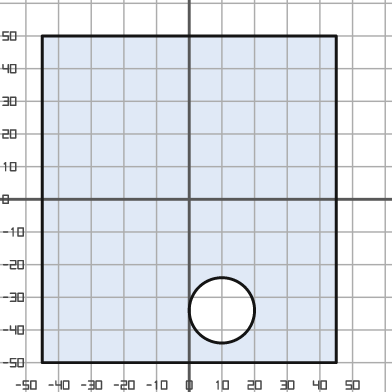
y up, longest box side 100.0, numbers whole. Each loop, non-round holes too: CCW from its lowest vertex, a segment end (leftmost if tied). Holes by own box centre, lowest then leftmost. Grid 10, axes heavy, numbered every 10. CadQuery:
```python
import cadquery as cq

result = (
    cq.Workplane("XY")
    .moveTo(-45.0, -50.0)
    .lineTo(45.0, -50.0)
    .lineTo(45.0, 50.0)
    .lineTo(-45.0, 50.0)
    .close()
    .moveTo(10.0, -34.0)
    .circle(10.0)
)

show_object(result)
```